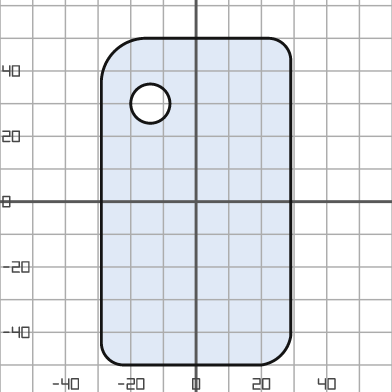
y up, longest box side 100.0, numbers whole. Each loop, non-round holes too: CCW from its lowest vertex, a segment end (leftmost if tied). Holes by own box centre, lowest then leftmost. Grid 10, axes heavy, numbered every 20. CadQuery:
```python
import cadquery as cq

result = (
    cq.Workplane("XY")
    .moveTo(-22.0, -50.0)
    .lineTo(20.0, -50.0)
    .threePointArc((26.0, -47.0), (29.0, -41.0))
    .lineTo(29.0, 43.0)
    .threePointArc((27.0, 48.0), (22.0, 50.0))
    .lineTo(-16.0, 50.0)
    .threePointArc((-25.0, 46.0), (-29.0, 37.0))
    .lineTo(-29.0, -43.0)
    .threePointArc((-27.0, -48.0), (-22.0, -50.0))
    .close()
    .moveTo(-14.0, 30.0)
    .circle(6.0)
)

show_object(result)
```